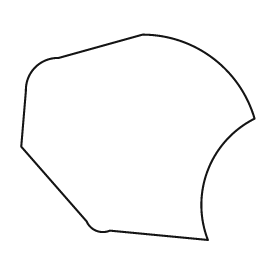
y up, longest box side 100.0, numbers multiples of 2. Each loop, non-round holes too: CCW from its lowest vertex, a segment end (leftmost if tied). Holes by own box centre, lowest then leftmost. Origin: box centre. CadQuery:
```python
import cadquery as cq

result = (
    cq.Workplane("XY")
    .moveTo(30.0, -44.0)
    .threePointArc((30.0, -14.0), (50.0, 8.0))
    .threePointArc((32.0, 34.0), (2.0, 44.0))
    .lineTo(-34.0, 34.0)
    .threePointArc((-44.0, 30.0), (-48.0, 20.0))
    .lineTo(-50.0, -4.0)
    .lineTo(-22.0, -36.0)
    .threePointArc((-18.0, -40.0), (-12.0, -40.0))
    .close()
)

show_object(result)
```